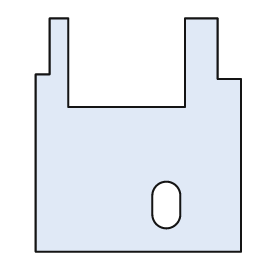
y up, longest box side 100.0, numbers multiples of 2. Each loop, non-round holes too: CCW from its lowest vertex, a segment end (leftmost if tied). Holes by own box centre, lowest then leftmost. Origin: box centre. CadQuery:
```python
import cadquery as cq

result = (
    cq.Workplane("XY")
    .moveTo(-44.0, -50.0)
    .lineTo(44.0, -50.0)
    .lineTo(44.0, 24.0)
    .lineTo(34.0, 24.0)
    .lineTo(34.0, 50.0)
    .lineTo(20.0, 50.0)
    .lineTo(20.0, 12.0)
    .lineTo(-30.0, 12.0)
    .lineTo(-30.0, 50.0)
    .lineTo(-38.0, 50.0)
    .lineTo(-38.0, 26.0)
    .lineTo(-44.0, 26.0)
    .close()
    .moveTo(6.0, -34.0)
    .threePointArc((12.0, -40.0), (18.0, -34.0))
    .lineTo(18.0, -26.0)
    .threePointArc((12.0, -20.0), (6.0, -26.0))
    .close()
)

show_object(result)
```